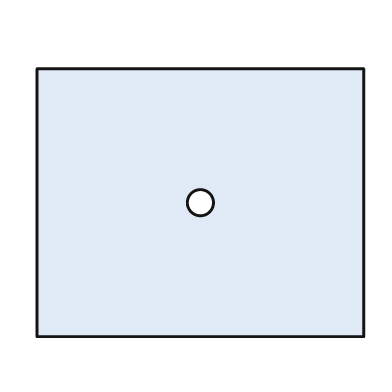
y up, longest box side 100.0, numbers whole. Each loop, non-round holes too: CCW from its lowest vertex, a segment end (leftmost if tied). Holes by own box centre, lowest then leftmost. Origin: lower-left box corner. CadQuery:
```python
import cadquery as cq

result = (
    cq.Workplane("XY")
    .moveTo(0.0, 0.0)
    .lineTo(100.0, 0.0)
    .lineTo(100.0, 82.0)
    .lineTo(0.0, 82.0)
    .close()
    .moveTo(50.0, 41.0)
    .circle(4.0)
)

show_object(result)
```